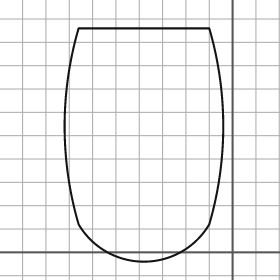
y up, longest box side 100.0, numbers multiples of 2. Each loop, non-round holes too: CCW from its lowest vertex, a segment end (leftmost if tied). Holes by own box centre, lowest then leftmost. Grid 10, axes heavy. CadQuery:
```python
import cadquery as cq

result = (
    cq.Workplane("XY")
    .moveTo(-66.0, 12.0)
    .threePointArc((-38.0, -4.0), (-10.0, 12.0))
    .threePointArc((-4.0, 54.0), (-10.0, 96.0))
    .lineTo(-66.0, 96.0)
    .threePointArc((-72.0, 54.0), (-66.0, 12.0))
    .close()
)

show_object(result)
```